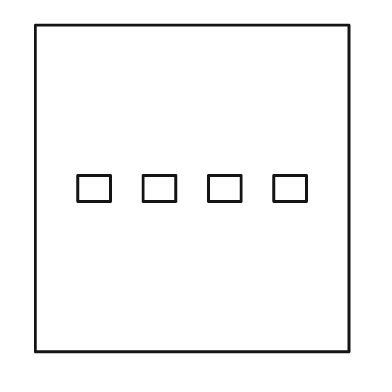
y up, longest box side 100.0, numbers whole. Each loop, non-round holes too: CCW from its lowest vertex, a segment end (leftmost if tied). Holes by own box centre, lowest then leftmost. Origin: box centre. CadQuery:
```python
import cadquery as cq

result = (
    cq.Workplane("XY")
    .moveTo(-48.0, -50.0)
    .lineTo(48.0, -50.0)
    .lineTo(48.0, 50.0)
    .lineTo(-48.0, 50.0)
    .close()
    .moveTo(-35.0, -4.0)
    .lineTo(-25.0, -4.0)
    .lineTo(-25.0, 4.0)
    .lineTo(-35.0, 4.0)
    .close()
    .moveTo(-15.0, -4.0)
    .lineTo(-5.0, -4.0)
    .lineTo(-5.0, 4.0)
    .lineTo(-15.0, 4.0)
    .close()
    .moveTo(5.0, -4.0)
    .lineTo(15.0, -4.0)
    .lineTo(15.0, 4.0)
    .lineTo(5.0, 4.0)
    .close()
    .moveTo(25.0, -4.0)
    .lineTo(35.0, -4.0)
    .lineTo(35.0, 4.0)
    .lineTo(25.0, 4.0)
    .close()
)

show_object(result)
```